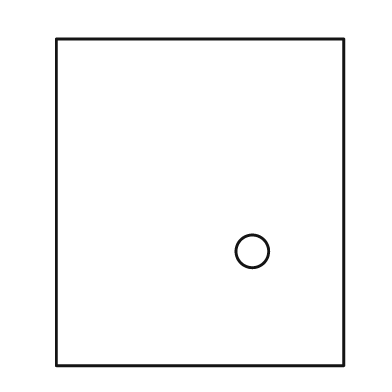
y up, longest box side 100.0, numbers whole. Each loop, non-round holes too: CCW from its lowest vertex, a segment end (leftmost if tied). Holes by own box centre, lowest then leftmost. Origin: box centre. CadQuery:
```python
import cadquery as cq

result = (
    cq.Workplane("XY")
    .moveTo(-44.0, -50.0)
    .lineTo(44.0, -50.0)
    .lineTo(44.0, 50.0)
    .lineTo(-44.0, 50.0)
    .close()
    .moveTo(16.0, -15.0)
    .circle(5.0)
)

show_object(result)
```